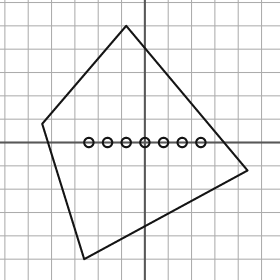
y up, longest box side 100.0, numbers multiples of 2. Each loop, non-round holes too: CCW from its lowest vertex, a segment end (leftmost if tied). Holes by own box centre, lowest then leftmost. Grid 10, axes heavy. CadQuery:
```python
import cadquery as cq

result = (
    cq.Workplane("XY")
    .moveTo(-26.0, -50.0)
    .lineTo(44.0, -12.0)
    .lineTo(-8.0, 50.0)
    .lineTo(-44.0, 8.0)
    .close()
    .moveTo(-24.0, 0.0)
    .circle(2.0)
    .moveTo(-16.0, 0.0)
    .circle(2.0)
    .moveTo(-8.0, 0.0)
    .circle(2.0)
    .moveTo(0.0, 0.0)
    .circle(2.0)
    .moveTo(8.0, 0.0)
    .circle(2.0)
    .moveTo(16.0, 0.0)
    .circle(2.0)
    .moveTo(24.0, 0.0)
    .circle(2.0)
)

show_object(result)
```